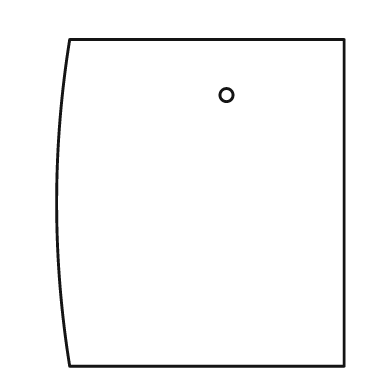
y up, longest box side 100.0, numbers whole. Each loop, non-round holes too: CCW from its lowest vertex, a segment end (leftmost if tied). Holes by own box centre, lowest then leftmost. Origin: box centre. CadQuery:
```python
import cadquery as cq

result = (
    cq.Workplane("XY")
    .moveTo(-40.0, -50.0)
    .lineTo(44.0, -50.0)
    .lineTo(44.0, 50.0)
    .lineTo(-40.0, 50.0)
    .threePointArc((-44.0, 0.0), (-40.0, -50.0))
    .close()
    .moveTo(8.0, 33.0)
    .circle(2.0)
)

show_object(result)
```